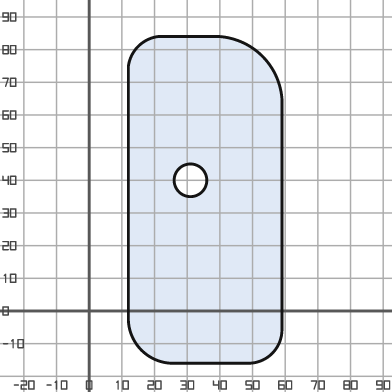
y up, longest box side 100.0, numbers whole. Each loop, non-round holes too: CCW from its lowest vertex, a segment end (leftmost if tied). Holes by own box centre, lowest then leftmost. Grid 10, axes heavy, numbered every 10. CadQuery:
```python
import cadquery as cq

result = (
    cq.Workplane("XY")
    .moveTo(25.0, -16.0)
    .lineTo(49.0, -16.0)
    .threePointArc((56.0, -13.0), (59.0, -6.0))
    .lineTo(59.0, 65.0)
    .threePointArc((53.0, 78.0), (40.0, 84.0))
    .lineTo(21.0, 84.0)
    .threePointArc((15.0, 81.0), (12.0, 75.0))
    .lineTo(12.0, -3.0)
    .threePointArc((16.0, -12.0), (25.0, -16.0))
    .close()
    .moveTo(31.0, 40.0)
    .circle(5.0)
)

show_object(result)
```